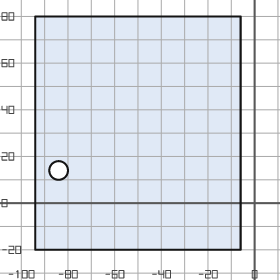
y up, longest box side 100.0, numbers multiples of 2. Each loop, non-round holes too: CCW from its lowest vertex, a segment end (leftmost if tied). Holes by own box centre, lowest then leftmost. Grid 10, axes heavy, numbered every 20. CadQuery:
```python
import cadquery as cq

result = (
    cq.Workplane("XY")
    .moveTo(-94.0, -20.0)
    .lineTo(-6.0, -20.0)
    .lineTo(-6.0, 80.0)
    .lineTo(-94.0, 80.0)
    .close()
    .moveTo(-84.0, 14.0)
    .circle(4.0)
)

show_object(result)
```